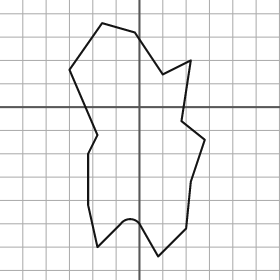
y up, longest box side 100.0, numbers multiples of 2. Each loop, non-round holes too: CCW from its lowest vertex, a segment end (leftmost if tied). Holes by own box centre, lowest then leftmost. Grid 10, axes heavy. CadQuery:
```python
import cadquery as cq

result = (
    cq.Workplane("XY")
    .moveTo(8.0, -64.0)
    .lineTo(20.0, -52.0)
    .lineTo(22.0, -32.0)
    .lineTo(28.0, -14.0)
    .lineTo(18.0, -6.0)
    .lineTo(22.0, 20.0)
    .lineTo(10.0, 14.0)
    .lineTo(-2.0, 32.0)
    .lineTo(-16.0, 36.0)
    .lineTo(-30.0, 16.0)
    .lineTo(-18.0, -12.0)
    .lineTo(-22.0, -20.0)
    .lineTo(-22.0, -42.0)
    .lineTo(-18.0, -60.0)
    .lineTo(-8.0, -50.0)
    .threePointArc((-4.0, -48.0), (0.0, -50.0))
    .close()
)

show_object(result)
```